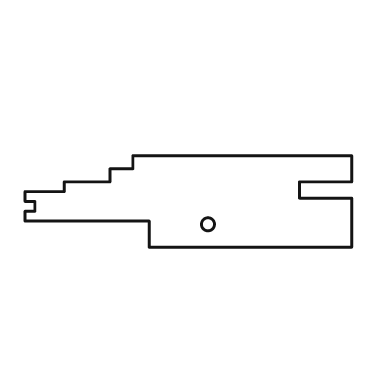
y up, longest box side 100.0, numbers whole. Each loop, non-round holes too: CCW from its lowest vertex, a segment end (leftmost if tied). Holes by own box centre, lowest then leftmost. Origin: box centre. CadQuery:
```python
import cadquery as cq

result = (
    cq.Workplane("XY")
    .moveTo(-12.0, -14.0)
    .lineTo(50.0, -14.0)
    .lineTo(50.0, 1.0)
    .lineTo(34.0, 1.0)
    .lineTo(34.0, 6.0)
    .lineTo(50.0, 6.0)
    .lineTo(50.0, 14.0)
    .lineTo(-17.0, 14.0)
    .lineTo(-17.0, 10.0)
    .lineTo(-24.0, 10.0)
    .lineTo(-24.0, 6.0)
    .lineTo(-38.0, 6.0)
    .lineTo(-38.0, 3.0)
    .lineTo(-50.0, 3.0)
    .lineTo(-50.0, 0.0)
    .lineTo(-47.0, 0.0)
    .lineTo(-47.0, -3.0)
    .lineTo(-50.0, -3.0)
    .lineTo(-50.0, -6.0)
    .lineTo(-12.0, -6.0)
    .close()
    .moveTo(6.0, -7.0)
    .circle(2.0)
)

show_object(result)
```